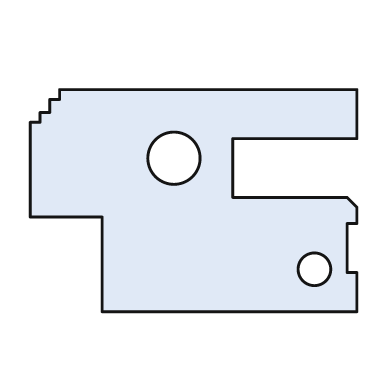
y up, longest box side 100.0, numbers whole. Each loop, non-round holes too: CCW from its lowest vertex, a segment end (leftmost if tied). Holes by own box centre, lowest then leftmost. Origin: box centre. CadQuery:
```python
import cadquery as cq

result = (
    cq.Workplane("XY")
    .moveTo(-28.0, -34.0)
    .lineTo(50.0, -34.0)
    .lineTo(50.0, -22.0)
    .lineTo(47.0, -22.0)
    .lineTo(47.0, -7.0)
    .lineTo(50.0, -7.0)
    .lineTo(50.0, -2.0)
    .lineTo(47.0, 1.0)
    .lineTo(12.0, 1.0)
    .lineTo(12.0, 19.0)
    .lineTo(50.0, 19.0)
    .lineTo(50.0, 34.0)
    .lineTo(-41.0, 34.0)
    .lineTo(-41.0, 31.0)
    .lineTo(-44.0, 31.0)
    .lineTo(-44.0, 27.0)
    .lineTo(-47.0, 27.0)
    .lineTo(-47.0, 24.0)
    .lineTo(-50.0, 24.0)
    .lineTo(-50.0, -5.0)
    .lineTo(-28.0, -5.0)
    .close()
    .moveTo(37.0, -21.0)
    .circle(5.0)
    .moveTo(-6.0, 13.0)
    .circle(8.0)
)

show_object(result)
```